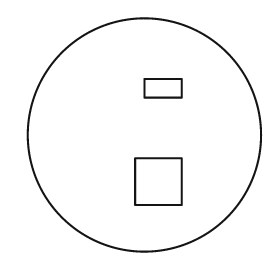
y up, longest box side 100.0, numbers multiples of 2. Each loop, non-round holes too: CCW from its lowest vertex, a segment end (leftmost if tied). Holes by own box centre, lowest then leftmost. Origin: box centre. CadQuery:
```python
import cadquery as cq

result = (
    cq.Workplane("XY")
    .moveTo(0.0, 0.0)
    .circle(50.0)
    .moveTo(-4.0, -30.0)
    .lineTo(16.0, -30.0)
    .lineTo(16.0, -10.0)
    .lineTo(-4.0, -10.0)
    .close()
    .moveTo(0.0, 16.0)
    .lineTo(16.0, 16.0)
    .lineTo(16.0, 24.0)
    .lineTo(0.0, 24.0)
    .close()
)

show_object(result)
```